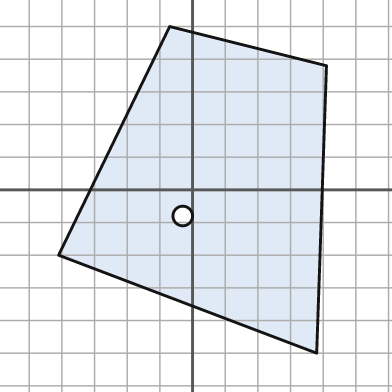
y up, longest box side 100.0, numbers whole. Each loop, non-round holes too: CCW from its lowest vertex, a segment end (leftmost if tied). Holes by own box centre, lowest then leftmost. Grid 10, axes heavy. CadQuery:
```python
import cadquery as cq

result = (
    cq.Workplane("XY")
    .moveTo(38.0, -50.0)
    .lineTo(41.0, 38.0)
    .lineTo(-7.0, 50.0)
    .lineTo(-41.0, -20.0)
    .close()
    .moveTo(-3.0, -8.0)
    .circle(3.0)
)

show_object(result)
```